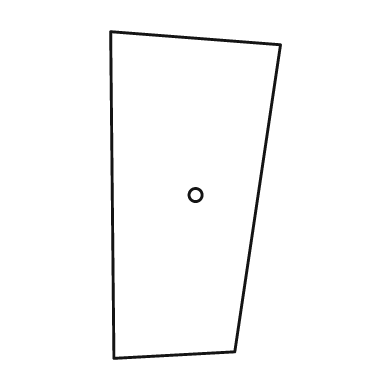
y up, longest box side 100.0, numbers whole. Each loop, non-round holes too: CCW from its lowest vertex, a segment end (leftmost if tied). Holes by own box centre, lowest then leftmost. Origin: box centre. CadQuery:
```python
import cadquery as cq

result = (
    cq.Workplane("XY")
    .moveTo(-25.0, -50.0)
    .lineTo(12.0, -48.0)
    .lineTo(26.0, 46.0)
    .lineTo(-26.0, 50.0)
    .close()
    .moveTo(0.0, 0.0)
    .circle(2.0)
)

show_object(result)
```